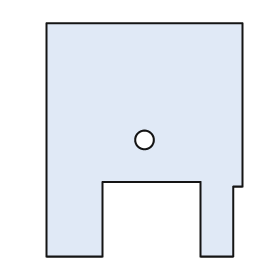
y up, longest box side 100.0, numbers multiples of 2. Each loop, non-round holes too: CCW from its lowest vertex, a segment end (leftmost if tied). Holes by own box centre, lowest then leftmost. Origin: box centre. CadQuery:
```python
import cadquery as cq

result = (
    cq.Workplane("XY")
    .moveTo(-42.0, -50.0)
    .lineTo(-18.0, -50.0)
    .lineTo(-18.0, -18.0)
    .lineTo(24.0, -18.0)
    .lineTo(24.0, -50.0)
    .lineTo(38.0, -50.0)
    .lineTo(38.0, -20.0)
    .lineTo(42.0, -20.0)
    .lineTo(42.0, 50.0)
    .lineTo(-42.0, 50.0)
    .close()
    .moveTo(0.0, 0.0)
    .circle(4.0)
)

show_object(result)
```